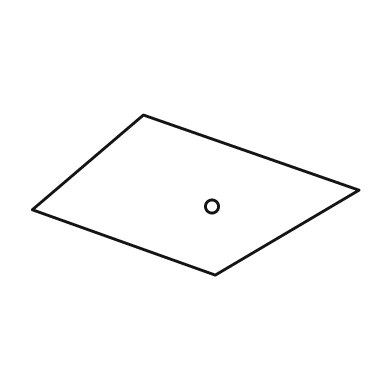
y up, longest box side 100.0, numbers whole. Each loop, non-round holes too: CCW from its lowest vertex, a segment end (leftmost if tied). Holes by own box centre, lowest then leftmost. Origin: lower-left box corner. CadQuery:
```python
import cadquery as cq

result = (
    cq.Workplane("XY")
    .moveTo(56.0, 0.0)
    .lineTo(100.0, 26.0)
    .lineTo(34.0, 49.0)
    .lineTo(0.0, 20.0)
    .close()
    .moveTo(55.0, 21.0)
    .circle(2.0)
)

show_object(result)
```